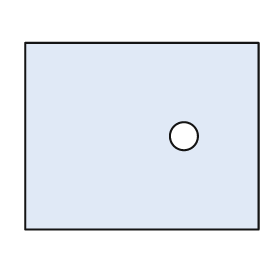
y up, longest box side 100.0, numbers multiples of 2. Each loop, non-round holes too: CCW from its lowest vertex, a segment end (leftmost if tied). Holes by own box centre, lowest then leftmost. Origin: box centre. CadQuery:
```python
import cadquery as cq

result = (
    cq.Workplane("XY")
    .moveTo(-50.0, -40.0)
    .lineTo(50.0, -40.0)
    .lineTo(50.0, 40.0)
    .lineTo(-50.0, 40.0)
    .close()
    .moveTo(18.0, 0.0)
    .circle(6.0)
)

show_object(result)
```